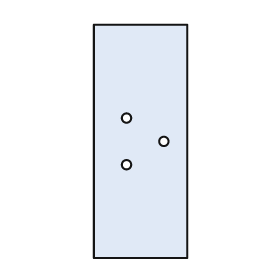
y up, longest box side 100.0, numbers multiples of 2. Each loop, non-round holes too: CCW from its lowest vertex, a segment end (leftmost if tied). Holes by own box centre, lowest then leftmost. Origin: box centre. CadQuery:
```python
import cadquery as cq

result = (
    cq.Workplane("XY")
    .moveTo(-20.0, -50.0)
    .lineTo(20.0, -50.0)
    .lineTo(20.0, 50.0)
    .lineTo(-20.0, 50.0)
    .close()
    .moveTo(-6.0, -10.0)
    .circle(2.0)
    .moveTo(10.0, 0.0)
    .circle(2.0)
    .moveTo(-6.0, 10.0)
    .circle(2.0)
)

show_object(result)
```